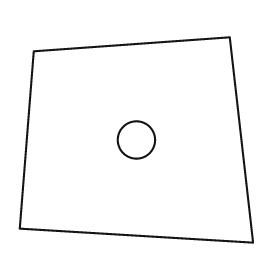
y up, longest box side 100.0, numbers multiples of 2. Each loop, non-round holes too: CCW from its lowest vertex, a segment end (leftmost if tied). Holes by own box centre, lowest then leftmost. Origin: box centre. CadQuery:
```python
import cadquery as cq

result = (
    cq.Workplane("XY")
    .moveTo(50.0, -44.0)
    .lineTo(40.0, 44.0)
    .lineTo(-44.0, 38.0)
    .lineTo(-50.0, -38.0)
    .close()
    .moveTo(0.0, 0.0)
    .circle(8.0)
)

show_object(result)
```